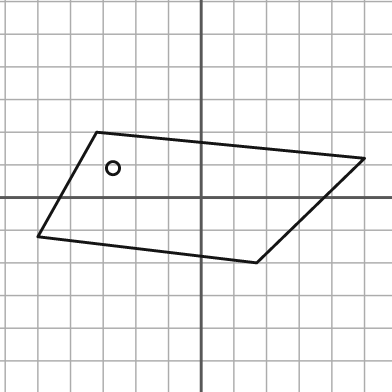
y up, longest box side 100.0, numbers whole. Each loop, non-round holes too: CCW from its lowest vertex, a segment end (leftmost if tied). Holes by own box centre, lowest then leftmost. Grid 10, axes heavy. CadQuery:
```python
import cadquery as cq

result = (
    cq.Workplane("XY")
    .moveTo(17.0, -20.0)
    .lineTo(50.0, 12.0)
    .lineTo(-32.0, 20.0)
    .lineTo(-50.0, -12.0)
    .close()
    .moveTo(-27.0, 9.0)
    .circle(2.0)
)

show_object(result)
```